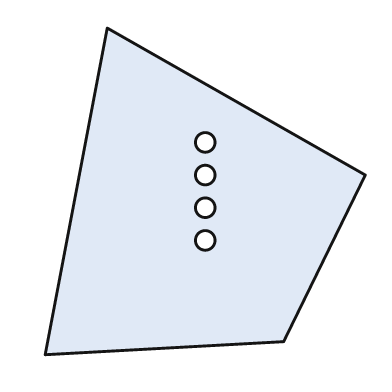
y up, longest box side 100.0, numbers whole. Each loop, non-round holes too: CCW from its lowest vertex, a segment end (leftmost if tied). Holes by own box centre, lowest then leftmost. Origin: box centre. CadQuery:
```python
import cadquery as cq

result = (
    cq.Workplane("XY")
    .moveTo(-49.0, -50.0)
    .lineTo(24.0, -46.0)
    .lineTo(49.0, 5.0)
    .lineTo(-30.0, 50.0)
    .close()
    .moveTo(0.0, -15.0)
    .circle(3.0)
    .moveTo(0.0, -5.0)
    .circle(3.0)
    .moveTo(0.0, 5.0)
    .circle(3.0)
    .moveTo(0.0, 15.0)
    .circle(3.0)
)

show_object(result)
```